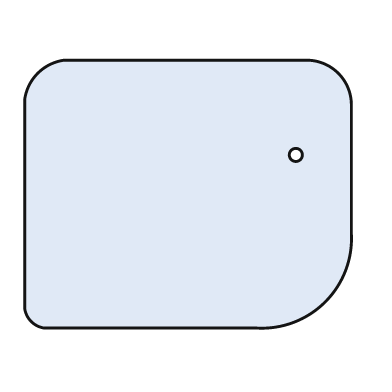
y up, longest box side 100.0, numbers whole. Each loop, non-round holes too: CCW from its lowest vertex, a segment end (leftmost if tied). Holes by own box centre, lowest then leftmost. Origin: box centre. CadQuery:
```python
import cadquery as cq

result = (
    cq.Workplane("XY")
    .moveTo(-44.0, -41.0)
    .lineTo(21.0, -41.0)
    .threePointArc((42.0, -33.0), (50.0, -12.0))
    .lineTo(50.0, 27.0)
    .threePointArc((46.0, 37.0), (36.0, 41.0))
    .lineTo(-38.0, 41.0)
    .threePointArc((-46.0, 37.0), (-50.0, 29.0))
    .lineTo(-50.0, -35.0)
    .threePointArc((-48.0, -39.0), (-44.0, -41.0))
    .close()
    .moveTo(33.0, 12.0)
    .circle(2.0)
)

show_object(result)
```